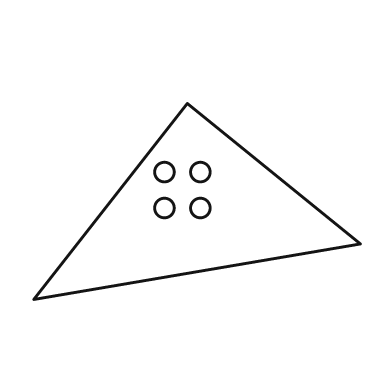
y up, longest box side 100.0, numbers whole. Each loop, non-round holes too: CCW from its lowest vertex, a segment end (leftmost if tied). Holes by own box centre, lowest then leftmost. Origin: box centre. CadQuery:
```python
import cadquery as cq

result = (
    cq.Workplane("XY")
    .moveTo(-50.0, -30.0)
    .lineTo(50.0, -13.0)
    .lineTo(-3.0, 30.0)
    .close()
    .moveTo(-10.0, -2.0)
    .circle(3.0)
    .moveTo(1.0, -2.0)
    .circle(3.0)
    .moveTo(-10.0, 9.0)
    .circle(3.0)
    .moveTo(1.0, 9.0)
    .circle(3.0)
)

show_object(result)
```